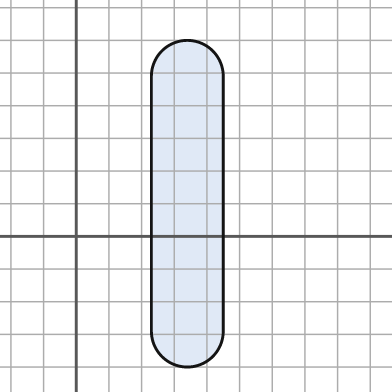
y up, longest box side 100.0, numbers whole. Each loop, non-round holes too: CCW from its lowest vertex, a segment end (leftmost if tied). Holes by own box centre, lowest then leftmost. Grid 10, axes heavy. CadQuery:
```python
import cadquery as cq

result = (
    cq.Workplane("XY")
    .moveTo(23.0, -29.0)
    .threePointArc((34.0, -40.0), (45.0, -29.0))
    .lineTo(45.0, 49.0)
    .threePointArc((34.0, 60.0), (23.0, 49.0))
    .close()
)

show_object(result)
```